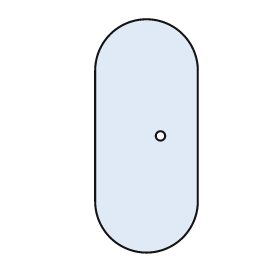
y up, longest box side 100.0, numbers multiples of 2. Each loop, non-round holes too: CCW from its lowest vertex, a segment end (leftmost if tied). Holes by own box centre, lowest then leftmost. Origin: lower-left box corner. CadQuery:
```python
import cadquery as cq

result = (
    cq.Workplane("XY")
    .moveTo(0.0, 22.0)
    .threePointArc((22.0, 0.0), (44.0, 22.0))
    .lineTo(44.0, 78.0)
    .threePointArc((22.0, 100.0), (0.0, 78.0))
    .close()
    .moveTo(28.0, 50.0)
    .circle(2.0)
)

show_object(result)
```